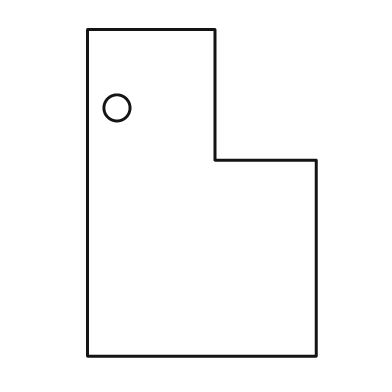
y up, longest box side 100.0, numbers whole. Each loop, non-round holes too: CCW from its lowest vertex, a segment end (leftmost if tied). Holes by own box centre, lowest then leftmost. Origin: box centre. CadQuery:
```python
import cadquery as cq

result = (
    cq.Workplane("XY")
    .moveTo(-35.0, -50.0)
    .lineTo(35.0, -50.0)
    .lineTo(35.0, 10.0)
    .lineTo(4.0, 10.0)
    .lineTo(4.0, 50.0)
    .lineTo(-35.0, 50.0)
    .close()
    .moveTo(-26.0, 26.0)
    .circle(4.0)
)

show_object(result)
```